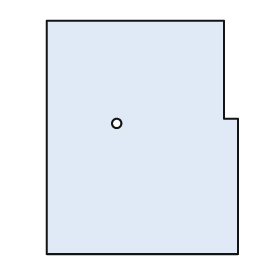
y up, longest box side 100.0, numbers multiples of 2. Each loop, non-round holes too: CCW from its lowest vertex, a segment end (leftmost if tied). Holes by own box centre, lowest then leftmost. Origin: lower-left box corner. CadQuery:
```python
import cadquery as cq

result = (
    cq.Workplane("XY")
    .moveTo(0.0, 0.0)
    .lineTo(82.0, 0.0)
    .lineTo(82.0, 58.0)
    .lineTo(76.0, 58.0)
    .lineTo(76.0, 100.0)
    .lineTo(0.0, 100.0)
    .close()
    .moveTo(30.0, 56.0)
    .circle(2.0)
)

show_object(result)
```